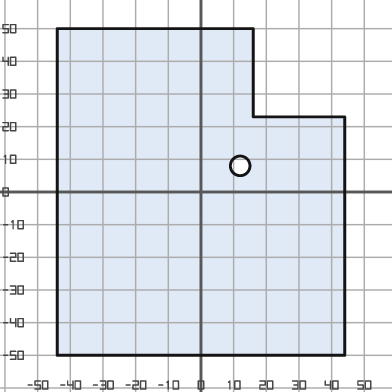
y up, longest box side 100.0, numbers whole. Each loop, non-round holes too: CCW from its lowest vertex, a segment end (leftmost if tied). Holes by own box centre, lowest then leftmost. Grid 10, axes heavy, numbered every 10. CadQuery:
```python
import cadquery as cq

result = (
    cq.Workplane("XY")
    .moveTo(-44.0, -50.0)
    .lineTo(44.0, -50.0)
    .lineTo(44.0, 23.0)
    .lineTo(16.0, 23.0)
    .lineTo(16.0, 50.0)
    .lineTo(-44.0, 50.0)
    .close()
    .moveTo(12.0, 8.0)
    .circle(3.0)
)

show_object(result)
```